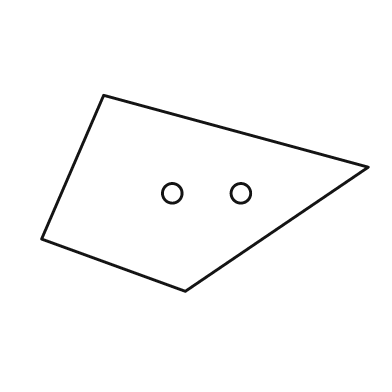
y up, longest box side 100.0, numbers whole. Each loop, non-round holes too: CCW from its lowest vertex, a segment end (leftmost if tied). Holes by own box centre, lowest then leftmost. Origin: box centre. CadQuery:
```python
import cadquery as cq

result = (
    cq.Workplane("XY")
    .moveTo(-6.0, -30.0)
    .lineTo(50.0, 8.0)
    .lineTo(-31.0, 30.0)
    .lineTo(-50.0, -14.0)
    .close()
    .moveTo(-10.0, 0.0)
    .circle(3.0)
    .moveTo(11.0, 0.0)
    .circle(3.0)
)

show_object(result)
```